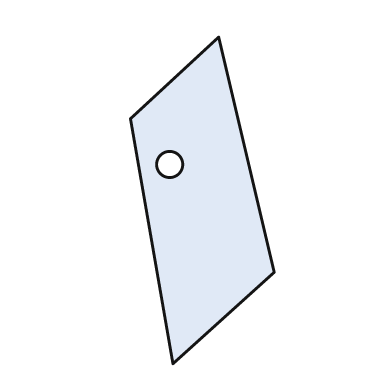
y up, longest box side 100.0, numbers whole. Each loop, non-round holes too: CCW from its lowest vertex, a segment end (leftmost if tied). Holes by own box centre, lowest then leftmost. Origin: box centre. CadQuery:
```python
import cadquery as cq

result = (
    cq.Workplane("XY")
    .moveTo(-9.0, -50.0)
    .lineTo(22.0, -22.0)
    .lineTo(5.0, 50.0)
    .lineTo(-22.0, 25.0)
    .close()
    .moveTo(-10.0, 11.0)
    .circle(4.0)
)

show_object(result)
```